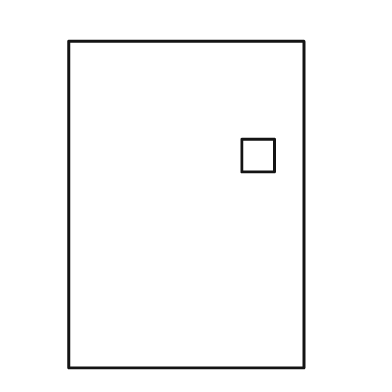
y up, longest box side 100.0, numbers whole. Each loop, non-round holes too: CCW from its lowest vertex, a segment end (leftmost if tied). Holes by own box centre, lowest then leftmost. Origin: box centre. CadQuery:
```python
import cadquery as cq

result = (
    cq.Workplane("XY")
    .moveTo(-36.0, -50.0)
    .lineTo(36.0, -50.0)
    .lineTo(36.0, 50.0)
    .lineTo(-36.0, 50.0)
    .close()
    .moveTo(17.0, 10.0)
    .lineTo(27.0, 10.0)
    .lineTo(27.0, 20.0)
    .lineTo(17.0, 20.0)
    .close()
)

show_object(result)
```